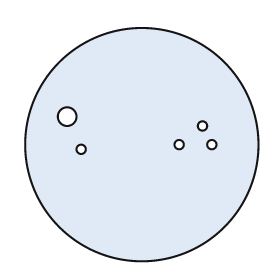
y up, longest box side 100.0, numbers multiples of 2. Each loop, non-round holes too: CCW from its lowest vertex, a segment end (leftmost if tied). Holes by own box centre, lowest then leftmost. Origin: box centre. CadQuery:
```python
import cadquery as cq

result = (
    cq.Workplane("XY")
    .moveTo(0.0, 0.0)
    .circle(50.0)
    .moveTo(-26.0, -2.0)
    .circle(2.0)
    .moveTo(16.0, 0.0)
    .circle(2.0)
    .moveTo(30.0, 0.0)
    .circle(2.0)
    .moveTo(26.0, 8.0)
    .circle(2.0)
    .moveTo(-32.0, 12.0)
    .circle(4.0)
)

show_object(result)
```